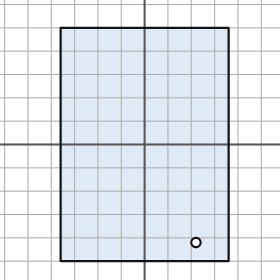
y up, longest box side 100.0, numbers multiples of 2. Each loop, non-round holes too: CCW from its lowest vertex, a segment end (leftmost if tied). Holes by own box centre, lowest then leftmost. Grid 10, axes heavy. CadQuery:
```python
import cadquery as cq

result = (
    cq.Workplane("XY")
    .moveTo(-36.0, -50.0)
    .lineTo(36.0, -50.0)
    .lineTo(36.0, 50.0)
    .lineTo(-36.0, 50.0)
    .close()
    .moveTo(22.0, -42.0)
    .circle(2.0)
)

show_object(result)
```